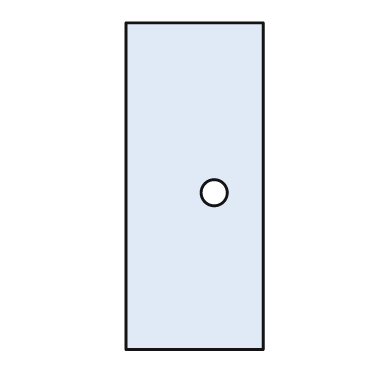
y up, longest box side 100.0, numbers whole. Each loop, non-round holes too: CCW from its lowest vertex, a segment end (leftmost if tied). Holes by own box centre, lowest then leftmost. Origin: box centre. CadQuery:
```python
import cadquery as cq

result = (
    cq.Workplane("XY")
    .moveTo(-21.0, -50.0)
    .lineTo(21.0, -50.0)
    .lineTo(21.0, 50.0)
    .lineTo(-21.0, 50.0)
    .close()
    .moveTo(6.0, -2.0)
    .circle(4.0)
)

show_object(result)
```